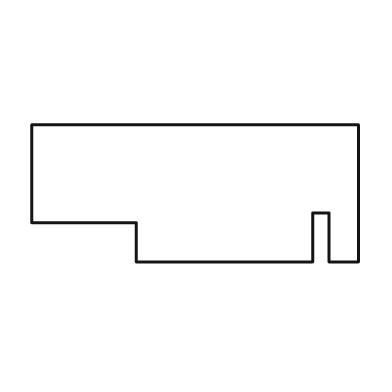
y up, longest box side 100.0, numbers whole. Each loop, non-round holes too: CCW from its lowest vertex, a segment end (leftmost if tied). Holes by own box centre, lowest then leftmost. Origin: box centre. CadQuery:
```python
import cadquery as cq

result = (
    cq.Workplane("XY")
    .moveTo(-18.0, -21.0)
    .lineTo(36.0, -21.0)
    .lineTo(36.0, -6.0)
    .lineTo(41.0, -6.0)
    .lineTo(41.0, -21.0)
    .lineTo(50.0, -21.0)
    .lineTo(50.0, 21.0)
    .lineTo(-50.0, 21.0)
    .lineTo(-50.0, -9.0)
    .lineTo(-18.0, -9.0)
    .close()
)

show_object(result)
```